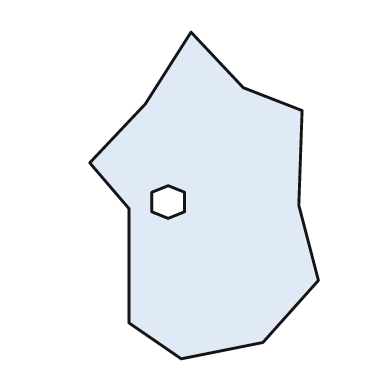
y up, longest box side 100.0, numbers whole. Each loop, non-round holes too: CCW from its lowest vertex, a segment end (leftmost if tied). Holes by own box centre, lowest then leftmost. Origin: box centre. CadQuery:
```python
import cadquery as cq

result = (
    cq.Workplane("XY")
    .moveTo(-7.0, -50.0)
    .lineTo(18.0, -45.0)
    .lineTo(35.0, -26.0)
    .lineTo(29.0, -3.0)
    .lineTo(30.0, 26.0)
    .lineTo(12.0, 33.0)
    .lineTo(-4.0, 50.0)
    .lineTo(-18.0, 28.0)
    .lineTo(-35.0, 10.0)
    .lineTo(-23.0, -4.0)
    .lineTo(-23.0, -39.0)
    .close()
    .moveTo(-11.0, -7.0)
    .lineTo(-6.0, -5.0)
    .lineTo(-6.0, 1.0)
    .lineTo(-11.0, 3.0)
    .lineTo(-16.0, 1.0)
    .lineTo(-16.0, -5.0)
    .close()
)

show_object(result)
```